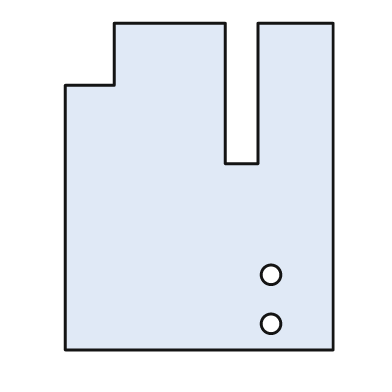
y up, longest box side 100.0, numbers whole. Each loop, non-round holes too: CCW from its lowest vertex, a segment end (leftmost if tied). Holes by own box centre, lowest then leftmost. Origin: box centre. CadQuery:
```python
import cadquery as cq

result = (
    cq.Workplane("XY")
    .moveTo(-41.0, -50.0)
    .lineTo(41.0, -50.0)
    .lineTo(41.0, 50.0)
    .lineTo(18.0, 50.0)
    .lineTo(18.0, 7.0)
    .lineTo(8.0, 7.0)
    .lineTo(8.0, 50.0)
    .lineTo(-26.0, 50.0)
    .lineTo(-26.0, 31.0)
    .lineTo(-41.0, 31.0)
    .close()
    .moveTo(22.0, -42.0)
    .circle(3.0)
    .moveTo(22.0, -27.0)
    .circle(3.0)
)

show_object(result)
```